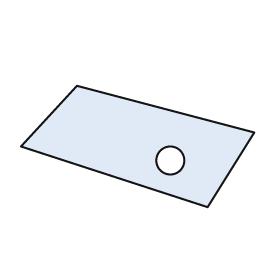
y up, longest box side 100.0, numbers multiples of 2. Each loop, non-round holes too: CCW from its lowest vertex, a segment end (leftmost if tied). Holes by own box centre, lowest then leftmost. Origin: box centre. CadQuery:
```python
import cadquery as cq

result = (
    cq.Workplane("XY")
    .moveTo(30.0, -26.0)
    .lineTo(50.0, 6.0)
    .lineTo(-26.0, 26.0)
    .lineTo(-50.0, 0.0)
    .close()
    .moveTo(14.0, -6.0)
    .circle(6.0)
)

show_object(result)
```